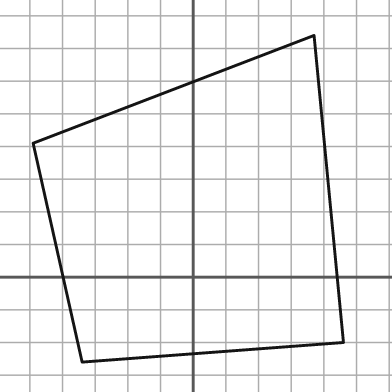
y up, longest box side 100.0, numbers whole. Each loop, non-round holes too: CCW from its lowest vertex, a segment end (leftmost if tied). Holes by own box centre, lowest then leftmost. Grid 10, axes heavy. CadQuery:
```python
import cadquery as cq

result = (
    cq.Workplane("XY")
    .moveTo(-34.0, -26.0)
    .lineTo(46.0, -20.0)
    .lineTo(37.0, 74.0)
    .lineTo(-49.0, 41.0)
    .close()
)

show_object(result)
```